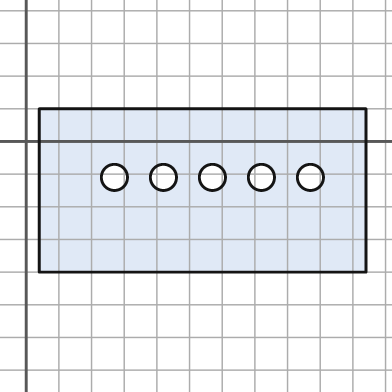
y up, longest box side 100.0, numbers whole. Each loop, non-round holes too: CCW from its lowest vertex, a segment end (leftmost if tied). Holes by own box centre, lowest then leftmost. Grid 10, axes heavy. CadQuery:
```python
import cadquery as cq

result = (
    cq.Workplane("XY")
    .moveTo(4.0, -40.0)
    .lineTo(104.0, -40.0)
    .lineTo(104.0, 10.0)
    .lineTo(4.0, 10.0)
    .close()
    .moveTo(27.0, -11.0)
    .circle(4.0)
    .moveTo(42.0, -11.0)
    .circle(4.0)
    .moveTo(57.0, -11.0)
    .circle(4.0)
    .moveTo(72.0, -11.0)
    .circle(4.0)
    .moveTo(87.0, -11.0)
    .circle(4.0)
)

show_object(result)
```